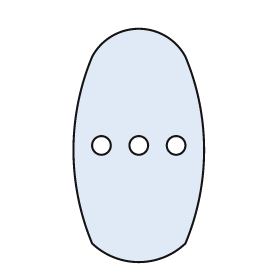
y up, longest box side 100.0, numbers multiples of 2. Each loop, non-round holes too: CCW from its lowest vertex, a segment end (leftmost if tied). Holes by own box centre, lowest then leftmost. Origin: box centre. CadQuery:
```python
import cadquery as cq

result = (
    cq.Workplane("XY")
    .moveTo(-20.0, -42.0)
    .threePointArc((0.0, -50.0), (20.0, -42.0))
    .threePointArc((28.0, -2.0), (20.0, 38.0))
    .threePointArc((0.0, 50.0), (-20.0, 38.0))
    .threePointArc((-28.0, -2.0), (-20.0, -42.0))
    .close()
    .moveTo(-16.0, 0.0)
    .circle(4.0)
    .moveTo(0.0, 0.0)
    .circle(4.0)
    .moveTo(16.0, 0.0)
    .circle(4.0)
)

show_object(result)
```